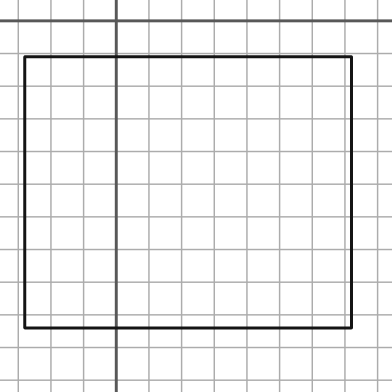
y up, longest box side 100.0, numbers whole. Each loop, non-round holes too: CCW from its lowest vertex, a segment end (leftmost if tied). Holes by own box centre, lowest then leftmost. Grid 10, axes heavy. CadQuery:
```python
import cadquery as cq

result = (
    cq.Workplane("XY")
    .moveTo(-28.0, -94.0)
    .lineTo(72.0, -94.0)
    .lineTo(72.0, -11.0)
    .lineTo(-28.0, -11.0)
    .close()
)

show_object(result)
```